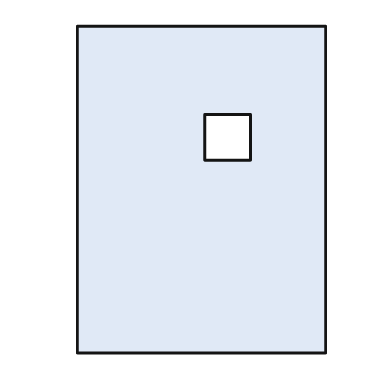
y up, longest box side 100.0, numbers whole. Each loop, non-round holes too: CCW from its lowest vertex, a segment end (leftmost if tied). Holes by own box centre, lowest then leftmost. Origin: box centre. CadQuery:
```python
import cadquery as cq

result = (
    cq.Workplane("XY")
    .moveTo(-38.0, -50.0)
    .lineTo(38.0, -50.0)
    .lineTo(38.0, 50.0)
    .lineTo(-38.0, 50.0)
    .close()
    .moveTo(1.0, 9.0)
    .lineTo(15.0, 9.0)
    .lineTo(15.0, 23.0)
    .lineTo(1.0, 23.0)
    .close()
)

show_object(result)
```